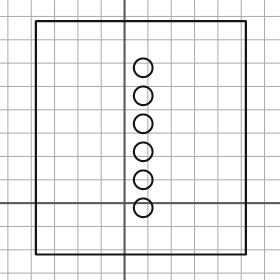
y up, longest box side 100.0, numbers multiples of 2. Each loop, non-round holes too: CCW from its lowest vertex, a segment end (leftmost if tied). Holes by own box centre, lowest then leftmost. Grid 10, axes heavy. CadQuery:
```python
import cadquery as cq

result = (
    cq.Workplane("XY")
    .moveTo(-38.0, -22.0)
    .lineTo(52.0, -22.0)
    .lineTo(52.0, 78.0)
    .lineTo(-38.0, 78.0)
    .close()
    .moveTo(8.0, -2.0)
    .circle(4.0)
    .moveTo(8.0, 10.0)
    .circle(4.0)
    .moveTo(8.0, 22.0)
    .circle(4.0)
    .moveTo(8.0, 34.0)
    .circle(4.0)
    .moveTo(8.0, 46.0)
    .circle(4.0)
    .moveTo(8.0, 58.0)
    .circle(4.0)
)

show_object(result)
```